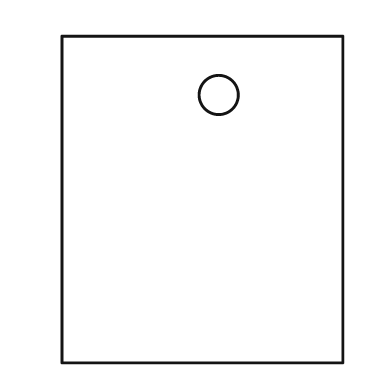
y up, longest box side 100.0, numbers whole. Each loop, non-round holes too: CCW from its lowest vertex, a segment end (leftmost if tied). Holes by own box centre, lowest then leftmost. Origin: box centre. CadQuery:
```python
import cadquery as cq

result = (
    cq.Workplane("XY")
    .moveTo(-43.0, -50.0)
    .lineTo(43.0, -50.0)
    .lineTo(43.0, 50.0)
    .lineTo(-43.0, 50.0)
    .close()
    .moveTo(5.0, 32.0)
    .circle(6.0)
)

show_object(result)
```